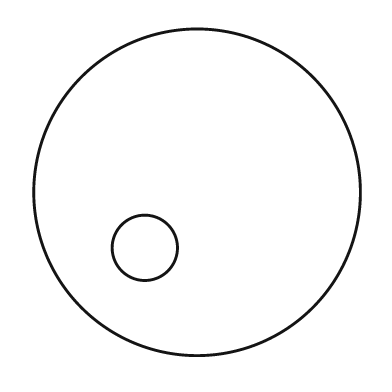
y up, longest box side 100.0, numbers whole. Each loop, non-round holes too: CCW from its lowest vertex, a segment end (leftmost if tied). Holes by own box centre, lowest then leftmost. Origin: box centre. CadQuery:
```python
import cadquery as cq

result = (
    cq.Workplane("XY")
    .moveTo(0.0, 0.0)
    .circle(50.0)
    .moveTo(-16.0, -17.0)
    .circle(10.0)
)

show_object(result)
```